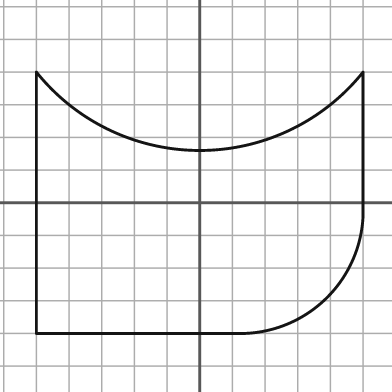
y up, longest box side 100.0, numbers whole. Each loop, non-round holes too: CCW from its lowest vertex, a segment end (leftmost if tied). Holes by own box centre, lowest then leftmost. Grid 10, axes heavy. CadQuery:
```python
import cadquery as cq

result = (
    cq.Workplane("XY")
    .moveTo(-50.0, -40.0)
    .lineTo(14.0, -40.0)
    .threePointArc((39.0, -29.0), (50.0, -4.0))
    .lineTo(50.0, 40.0)
    .threePointArc((0.0, 16.0), (-50.0, 40.0))
    .close()
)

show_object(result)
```